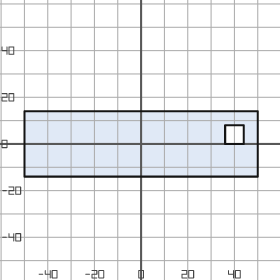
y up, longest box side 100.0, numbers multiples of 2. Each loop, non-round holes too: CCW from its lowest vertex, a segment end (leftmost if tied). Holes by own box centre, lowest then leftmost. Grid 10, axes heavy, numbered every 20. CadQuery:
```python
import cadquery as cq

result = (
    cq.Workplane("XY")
    .moveTo(-50.0, -14.0)
    .lineTo(50.0, -14.0)
    .lineTo(50.0, 14.0)
    .lineTo(-50.0, 14.0)
    .close()
    .moveTo(36.0, 0.0)
    .lineTo(44.0, 0.0)
    .lineTo(44.0, 8.0)
    .lineTo(36.0, 8.0)
    .close()
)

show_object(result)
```